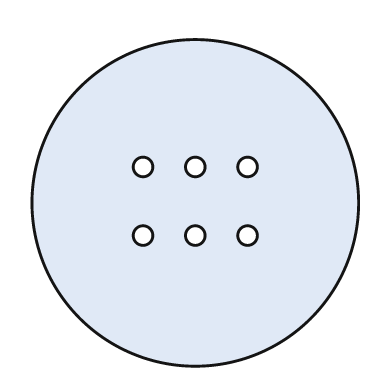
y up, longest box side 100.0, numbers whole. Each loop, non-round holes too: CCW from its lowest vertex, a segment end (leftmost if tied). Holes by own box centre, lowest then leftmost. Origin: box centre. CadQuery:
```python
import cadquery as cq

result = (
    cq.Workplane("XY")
    .moveTo(0.0, 0.0)
    .circle(50.0)
    .moveTo(-16.0, -10.0)
    .circle(3.0)
    .moveTo(0.0, -10.0)
    .circle(3.0)
    .moveTo(16.0, -10.0)
    .circle(3.0)
    .moveTo(-16.0, 11.0)
    .circle(3.0)
    .moveTo(0.0, 11.0)
    .circle(3.0)
    .moveTo(16.0, 11.0)
    .circle(3.0)
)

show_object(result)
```